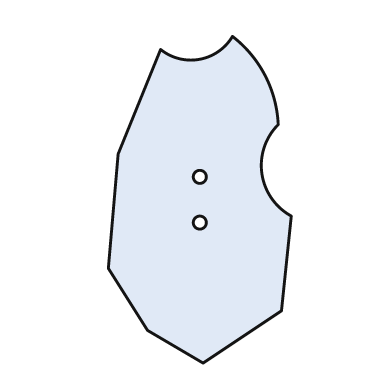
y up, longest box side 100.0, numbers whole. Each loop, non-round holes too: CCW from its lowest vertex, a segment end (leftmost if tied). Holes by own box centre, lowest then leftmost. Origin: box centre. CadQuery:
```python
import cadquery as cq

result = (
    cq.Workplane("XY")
    .moveTo(1.0, -50.0)
    .lineTo(25.0, -34.0)
    .lineTo(28.0, -5.0)
    .threePointArc((19.0, 8.0), (24.0, 23.0))
    .threePointArc((20.0, 38.0), (10.0, 50.0))
    .threePointArc((0.0, 43.0), (-12.0, 46.0))
    .lineTo(-25.0, 14.0)
    .lineTo(-28.0, -21.0)
    .lineTo(-16.0, -40.0)
    .close()
    .moveTo(0.0, -7.0)
    .circle(2.0)
    .moveTo(0.0, 7.0)
    .circle(2.0)
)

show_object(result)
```